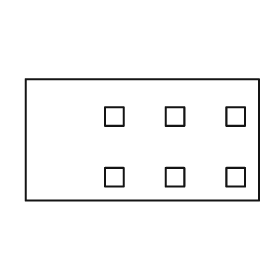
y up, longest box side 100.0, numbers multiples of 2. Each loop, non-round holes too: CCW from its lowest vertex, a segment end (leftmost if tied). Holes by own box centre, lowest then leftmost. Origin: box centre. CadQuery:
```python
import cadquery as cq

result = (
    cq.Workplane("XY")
    .moveTo(-50.0, -26.0)
    .lineTo(50.0, -26.0)
    .lineTo(50.0, 26.0)
    .lineTo(-50.0, 26.0)
    .close()
    .moveTo(-16.0, -20.0)
    .lineTo(-8.0, -20.0)
    .lineTo(-8.0, -12.0)
    .lineTo(-16.0, -12.0)
    .close()
    .moveTo(10.0, -20.0)
    .lineTo(18.0, -20.0)
    .lineTo(18.0, -12.0)
    .lineTo(10.0, -12.0)
    .close()
    .moveTo(36.0, -20.0)
    .lineTo(44.0, -20.0)
    .lineTo(44.0, -12.0)
    .lineTo(36.0, -12.0)
    .close()
    .moveTo(-16.0, 6.0)
    .lineTo(-8.0, 6.0)
    .lineTo(-8.0, 14.0)
    .lineTo(-16.0, 14.0)
    .close()
    .moveTo(10.0, 6.0)
    .lineTo(18.0, 6.0)
    .lineTo(18.0, 14.0)
    .lineTo(10.0, 14.0)
    .close()
    .moveTo(36.0, 6.0)
    .lineTo(44.0, 6.0)
    .lineTo(44.0, 14.0)
    .lineTo(36.0, 14.0)
    .close()
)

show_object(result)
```